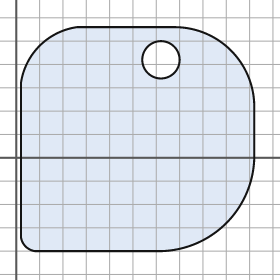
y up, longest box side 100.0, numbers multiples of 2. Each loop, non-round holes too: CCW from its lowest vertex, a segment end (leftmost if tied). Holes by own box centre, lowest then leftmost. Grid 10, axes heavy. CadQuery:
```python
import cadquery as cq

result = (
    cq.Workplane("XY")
    .moveTo(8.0, -40.0)
    .lineTo(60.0, -40.0)
    .threePointArc((90.0, -28.0), (102.0, 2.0))
    .lineTo(102.0, 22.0)
    .threePointArc((92.0, 46.0), (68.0, 56.0))
    .lineTo(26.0, 56.0)
    .threePointArc((10.0, 48.0), (2.0, 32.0))
    .lineTo(2.0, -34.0)
    .threePointArc((4.0, -38.0), (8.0, -40.0))
    .close()
    .moveTo(62.0, 42.0)
    .circle(8.0)
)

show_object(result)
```